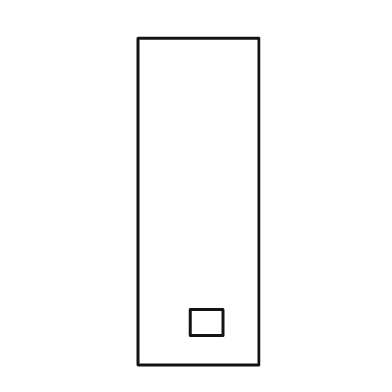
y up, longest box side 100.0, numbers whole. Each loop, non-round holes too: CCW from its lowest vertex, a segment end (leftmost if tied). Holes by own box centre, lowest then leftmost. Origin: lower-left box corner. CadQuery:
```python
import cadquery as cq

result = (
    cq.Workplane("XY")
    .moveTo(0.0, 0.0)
    .lineTo(37.0, 0.0)
    .lineTo(37.0, 100.0)
    .lineTo(0.0, 100.0)
    .close()
    .moveTo(16.0, 9.0)
    .lineTo(26.0, 9.0)
    .lineTo(26.0, 17.0)
    .lineTo(16.0, 17.0)
    .close()
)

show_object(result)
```